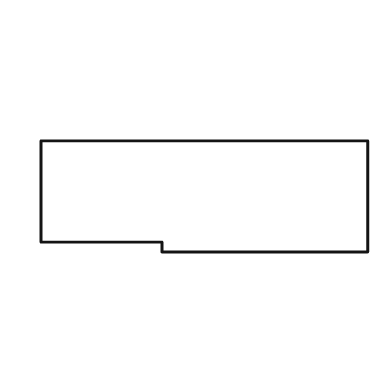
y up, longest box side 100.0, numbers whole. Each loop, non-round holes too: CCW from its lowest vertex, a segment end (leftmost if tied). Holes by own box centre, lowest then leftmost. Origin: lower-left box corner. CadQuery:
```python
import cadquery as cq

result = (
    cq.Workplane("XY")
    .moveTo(37.0, 0.0)
    .lineTo(100.0, 0.0)
    .lineTo(100.0, 34.0)
    .lineTo(0.0, 34.0)
    .lineTo(0.0, 3.0)
    .lineTo(37.0, 3.0)
    .close()
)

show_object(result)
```